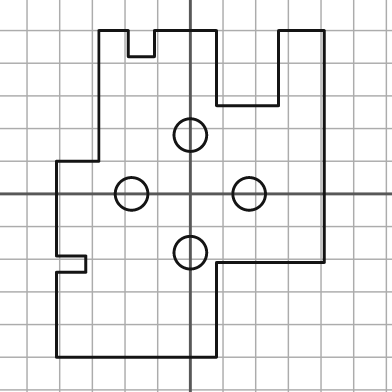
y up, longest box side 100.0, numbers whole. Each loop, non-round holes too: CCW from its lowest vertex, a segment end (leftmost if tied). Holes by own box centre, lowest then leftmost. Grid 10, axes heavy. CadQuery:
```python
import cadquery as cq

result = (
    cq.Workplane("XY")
    .moveTo(-41.0, -50.0)
    .lineTo(8.0, -50.0)
    .lineTo(8.0, -21.0)
    .lineTo(41.0, -21.0)
    .lineTo(41.0, 50.0)
    .lineTo(27.0, 50.0)
    .lineTo(27.0, 27.0)
    .lineTo(8.0, 27.0)
    .lineTo(8.0, 50.0)
    .lineTo(-11.0, 50.0)
    .lineTo(-11.0, 42.0)
    .lineTo(-19.0, 42.0)
    .lineTo(-19.0, 50.0)
    .lineTo(-28.0, 50.0)
    .lineTo(-28.0, 10.0)
    .lineTo(-41.0, 10.0)
    .lineTo(-41.0, -19.0)
    .lineTo(-32.0, -19.0)
    .lineTo(-32.0, -24.0)
    .lineTo(-41.0, -24.0)
    .close()
    .moveTo(0.0, -18.0)
    .circle(5.0)
    .moveTo(-18.0, 0.0)
    .circle(5.0)
    .moveTo(18.0, 0.0)
    .circle(5.0)
    .moveTo(0.0, 18.0)
    .circle(5.0)
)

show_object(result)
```